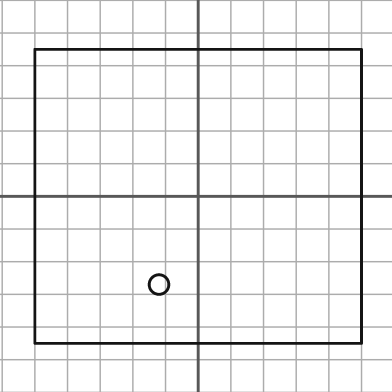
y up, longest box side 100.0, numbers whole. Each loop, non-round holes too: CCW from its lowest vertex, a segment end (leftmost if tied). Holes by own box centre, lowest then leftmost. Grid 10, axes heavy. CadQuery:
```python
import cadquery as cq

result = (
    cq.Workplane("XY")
    .moveTo(-50.0, -45.0)
    .lineTo(50.0, -45.0)
    .lineTo(50.0, 45.0)
    .lineTo(-50.0, 45.0)
    .close()
    .moveTo(-12.0, -27.0)
    .circle(3.0)
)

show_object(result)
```